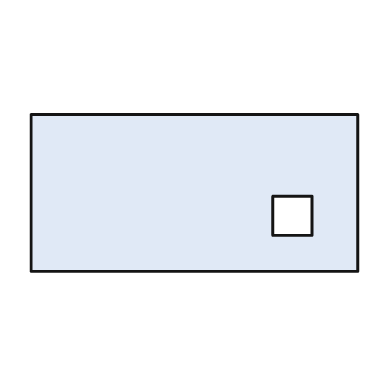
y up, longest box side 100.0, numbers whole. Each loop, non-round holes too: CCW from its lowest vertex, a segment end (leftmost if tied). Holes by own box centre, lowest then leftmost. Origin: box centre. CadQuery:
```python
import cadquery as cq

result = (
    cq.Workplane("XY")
    .moveTo(-50.0, -24.0)
    .lineTo(50.0, -24.0)
    .lineTo(50.0, 24.0)
    .lineTo(-50.0, 24.0)
    .close()
    .moveTo(24.0, -13.0)
    .lineTo(36.0, -13.0)
    .lineTo(36.0, -1.0)
    .lineTo(24.0, -1.0)
    .close()
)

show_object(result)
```